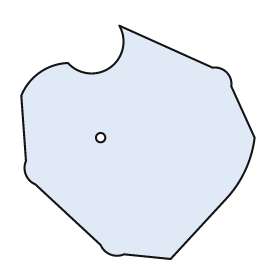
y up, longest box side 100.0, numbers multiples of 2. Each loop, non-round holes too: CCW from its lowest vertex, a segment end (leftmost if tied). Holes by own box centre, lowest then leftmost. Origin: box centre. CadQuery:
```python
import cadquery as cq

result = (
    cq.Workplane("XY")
    .moveTo(14.0, -50.0)
    .lineTo(38.0, -24.0)
    .threePointArc((46.0, -12.0), (50.0, 2.0))
    .lineTo(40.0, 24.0)
    .threePointArc((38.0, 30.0), (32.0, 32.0))
    .lineTo(-8.0, 50.0)
    .threePointArc((-12.0, 32.0), (-30.0, 34.0))
    .threePointArc((-42.0, 30.0), (-50.0, 20.0))
    .lineTo(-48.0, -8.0)
    .threePointArc((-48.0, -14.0), (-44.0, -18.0))
    .lineTo(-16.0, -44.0)
    .threePointArc((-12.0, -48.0), (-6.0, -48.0))
    .close()
    .moveTo(-16.0, 2.0)
    .circle(2.0)
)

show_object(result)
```